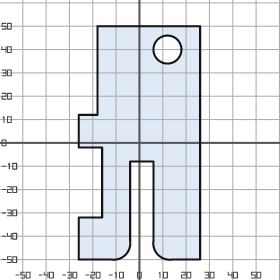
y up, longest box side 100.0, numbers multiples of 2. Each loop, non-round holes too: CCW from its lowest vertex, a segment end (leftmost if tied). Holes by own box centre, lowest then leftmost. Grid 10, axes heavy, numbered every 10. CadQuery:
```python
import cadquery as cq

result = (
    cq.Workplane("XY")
    .moveTo(-26.0, -50.0)
    .lineTo(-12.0, -50.0)
    .threePointArc((-6.0, -48.0), (-4.0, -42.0))
    .lineTo(-4.0, -8.0)
    .lineTo(6.0, -8.0)
    .lineTo(6.0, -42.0)
    .threePointArc((8.0, -48.0), (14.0, -50.0))
    .lineTo(26.0, -50.0)
    .lineTo(26.0, 50.0)
    .lineTo(-18.0, 50.0)
    .lineTo(-18.0, 12.0)
    .lineTo(-26.0, 12.0)
    .lineTo(-26.0, -2.0)
    .lineTo(-16.0, -2.0)
    .lineTo(-16.0, -32.0)
    .lineTo(-26.0, -32.0)
    .close()
    .moveTo(12.0, 40.0)
    .circle(6.0)
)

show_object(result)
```